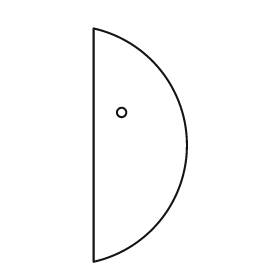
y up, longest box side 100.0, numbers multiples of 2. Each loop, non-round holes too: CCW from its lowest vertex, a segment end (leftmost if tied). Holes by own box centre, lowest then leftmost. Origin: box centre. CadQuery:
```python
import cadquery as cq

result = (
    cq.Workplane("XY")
    .moveTo(-20.0, -50.0)
    .threePointArc((20.0, 0.0), (-20.0, 50.0))
    .close()
    .moveTo(-8.0, 14.0)
    .circle(2.0)
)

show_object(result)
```